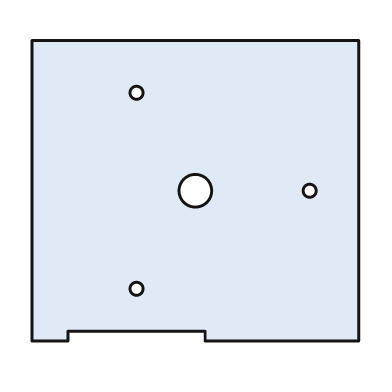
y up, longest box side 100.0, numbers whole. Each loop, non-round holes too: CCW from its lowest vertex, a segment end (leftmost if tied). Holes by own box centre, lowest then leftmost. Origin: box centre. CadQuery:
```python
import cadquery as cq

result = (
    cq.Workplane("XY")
    .moveTo(-50.0, -46.0)
    .lineTo(-39.0, -46.0)
    .lineTo(-39.0, -43.0)
    .lineTo(3.0, -43.0)
    .lineTo(3.0, -46.0)
    .lineTo(50.0, -46.0)
    .lineTo(50.0, 46.0)
    .lineTo(-50.0, 46.0)
    .close()
    .moveTo(-18.0, -30.0)
    .circle(2.0)
    .moveTo(0.0, 0.0)
    .circle(5.0)
    .moveTo(35.0, 0.0)
    .circle(2.0)
    .moveTo(-18.0, 30.0)
    .circle(2.0)
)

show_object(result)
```